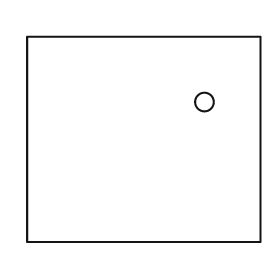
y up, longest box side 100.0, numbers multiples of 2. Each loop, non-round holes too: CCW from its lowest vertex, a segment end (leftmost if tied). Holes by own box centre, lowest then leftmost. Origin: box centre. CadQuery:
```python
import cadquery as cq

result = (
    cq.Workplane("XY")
    .moveTo(-50.0, -44.0)
    .lineTo(50.0, -44.0)
    .lineTo(50.0, 44.0)
    .lineTo(-50.0, 44.0)
    .close()
    .moveTo(26.0, 16.0)
    .circle(4.0)
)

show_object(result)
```